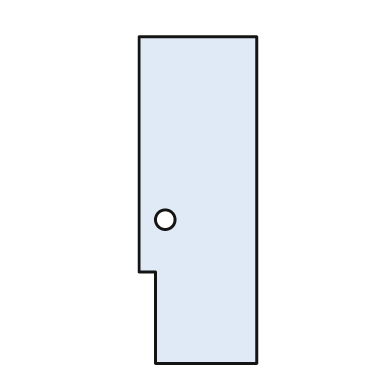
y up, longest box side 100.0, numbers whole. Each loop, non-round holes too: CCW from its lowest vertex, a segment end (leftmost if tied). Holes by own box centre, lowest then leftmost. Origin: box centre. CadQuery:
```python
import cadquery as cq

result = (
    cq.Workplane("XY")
    .moveTo(-13.0, -50.0)
    .lineTo(18.0, -50.0)
    .lineTo(18.0, 50.0)
    .lineTo(-18.0, 50.0)
    .lineTo(-18.0, -22.0)
    .lineTo(-13.0, -22.0)
    .close()
    .moveTo(-10.0, -6.0)
    .circle(3.0)
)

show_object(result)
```